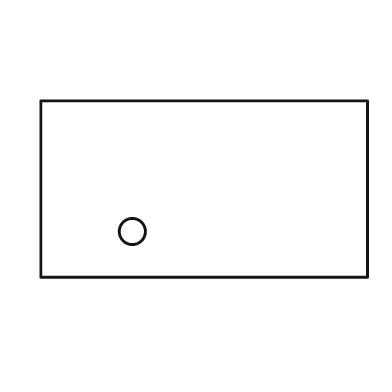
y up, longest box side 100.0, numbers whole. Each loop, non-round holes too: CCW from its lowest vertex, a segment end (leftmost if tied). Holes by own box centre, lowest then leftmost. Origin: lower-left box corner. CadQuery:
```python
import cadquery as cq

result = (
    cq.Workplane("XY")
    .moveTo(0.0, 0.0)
    .lineTo(100.0, 0.0)
    .lineTo(100.0, 54.0)
    .lineTo(0.0, 54.0)
    .close()
    .moveTo(28.0, 14.0)
    .circle(4.0)
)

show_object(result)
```